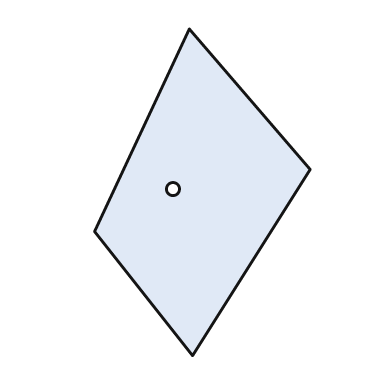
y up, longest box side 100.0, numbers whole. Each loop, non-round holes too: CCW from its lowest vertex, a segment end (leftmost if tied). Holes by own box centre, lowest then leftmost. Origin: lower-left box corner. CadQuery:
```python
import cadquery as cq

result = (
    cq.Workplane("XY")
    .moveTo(30.0, 0.0)
    .lineTo(66.0, 57.0)
    .lineTo(29.0, 100.0)
    .lineTo(0.0, 38.0)
    .close()
    .moveTo(24.0, 51.0)
    .circle(2.0)
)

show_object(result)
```